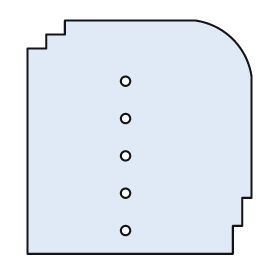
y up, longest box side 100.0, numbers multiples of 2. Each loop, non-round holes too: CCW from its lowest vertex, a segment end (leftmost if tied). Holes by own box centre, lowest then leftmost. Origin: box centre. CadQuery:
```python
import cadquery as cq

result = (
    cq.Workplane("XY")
    .moveTo(-48.0, -50.0)
    .lineTo(40.0, -50.0)
    .lineTo(40.0, -38.0)
    .lineTo(44.0, -38.0)
    .lineTo(44.0, -26.0)
    .lineTo(48.0, -26.0)
    .lineTo(48.0, 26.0)
    .threePointArc((40.0, 42.0), (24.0, 50.0))
    .lineTo(-32.0, 50.0)
    .lineTo(-32.0, 44.0)
    .lineTo(-40.0, 44.0)
    .lineTo(-40.0, 38.0)
    .lineTo(-48.0, 38.0)
    .close()
    .moveTo(-6.0, -40.0)
    .circle(2.0)
    .moveTo(-6.0, -24.0)
    .circle(2.0)
    .moveTo(-6.0, -8.0)
    .circle(2.0)
    .moveTo(-6.0, 8.0)
    .circle(2.0)
    .moveTo(-6.0, 24.0)
    .circle(2.0)
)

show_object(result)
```